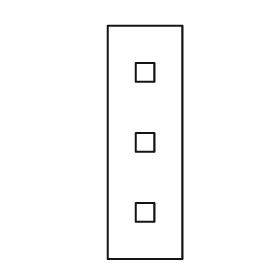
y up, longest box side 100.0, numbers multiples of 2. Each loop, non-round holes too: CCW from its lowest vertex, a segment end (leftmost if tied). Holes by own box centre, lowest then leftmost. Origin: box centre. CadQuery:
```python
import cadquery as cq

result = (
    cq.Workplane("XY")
    .moveTo(-16.0, -50.0)
    .lineTo(16.0, -50.0)
    .lineTo(16.0, 50.0)
    .lineTo(-16.0, 50.0)
    .close()
    .moveTo(-4.0, -34.0)
    .lineTo(4.0, -34.0)
    .lineTo(4.0, -26.0)
    .lineTo(-4.0, -26.0)
    .close()
    .moveTo(-4.0, -4.0)
    .lineTo(4.0, -4.0)
    .lineTo(4.0, 4.0)
    .lineTo(-4.0, 4.0)
    .close()
    .moveTo(-4.0, 26.0)
    .lineTo(4.0, 26.0)
    .lineTo(4.0, 34.0)
    .lineTo(-4.0, 34.0)
    .close()
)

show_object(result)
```